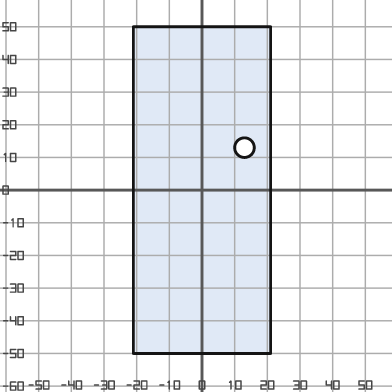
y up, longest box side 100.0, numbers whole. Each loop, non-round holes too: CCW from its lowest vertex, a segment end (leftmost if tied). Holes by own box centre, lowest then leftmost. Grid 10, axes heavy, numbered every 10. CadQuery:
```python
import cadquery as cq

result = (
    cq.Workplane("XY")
    .moveTo(-21.0, -50.0)
    .lineTo(21.0, -50.0)
    .lineTo(21.0, 50.0)
    .lineTo(-21.0, 50.0)
    .close()
    .moveTo(13.0, 13.0)
    .circle(3.0)
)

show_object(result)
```